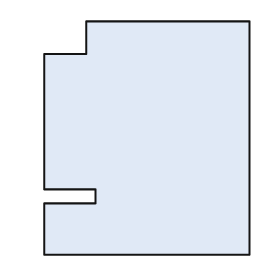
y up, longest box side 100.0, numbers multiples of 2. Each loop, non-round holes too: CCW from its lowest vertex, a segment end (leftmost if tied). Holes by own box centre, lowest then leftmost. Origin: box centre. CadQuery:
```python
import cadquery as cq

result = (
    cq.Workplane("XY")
    .moveTo(-44.0, -50.0)
    .lineTo(44.0, -50.0)
    .lineTo(44.0, 50.0)
    .lineTo(-26.0, 50.0)
    .lineTo(-26.0, 36.0)
    .lineTo(-44.0, 36.0)
    .lineTo(-44.0, -22.0)
    .lineTo(-22.0, -22.0)
    .lineTo(-22.0, -28.0)
    .lineTo(-44.0, -28.0)
    .close()
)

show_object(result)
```